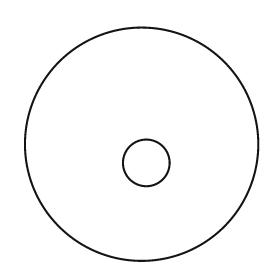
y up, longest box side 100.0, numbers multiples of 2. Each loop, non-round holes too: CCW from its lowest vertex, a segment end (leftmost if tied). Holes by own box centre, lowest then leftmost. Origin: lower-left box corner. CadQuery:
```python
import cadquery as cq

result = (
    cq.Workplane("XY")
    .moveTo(50.0, 50.0)
    .circle(50.0)
    .moveTo(52.0, 42.0)
    .circle(10.0)
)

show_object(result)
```